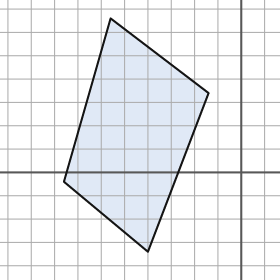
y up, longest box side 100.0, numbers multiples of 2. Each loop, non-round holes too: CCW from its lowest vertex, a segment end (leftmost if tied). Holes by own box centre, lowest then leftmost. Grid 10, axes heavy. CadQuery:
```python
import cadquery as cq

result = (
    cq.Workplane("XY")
    .moveTo(-40.0, -34.0)
    .lineTo(-14.0, 34.0)
    .lineTo(-56.0, 66.0)
    .lineTo(-76.0, -4.0)
    .close()
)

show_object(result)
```